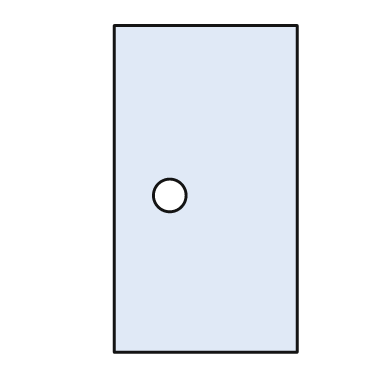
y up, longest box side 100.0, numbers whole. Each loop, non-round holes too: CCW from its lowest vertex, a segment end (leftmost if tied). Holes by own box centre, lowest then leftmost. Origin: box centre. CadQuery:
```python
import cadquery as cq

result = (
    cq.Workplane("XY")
    .moveTo(-28.0, -50.0)
    .lineTo(28.0, -50.0)
    .lineTo(28.0, 50.0)
    .lineTo(-28.0, 50.0)
    .close()
    .moveTo(-11.0, -2.0)
    .circle(5.0)
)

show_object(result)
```